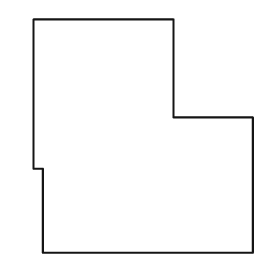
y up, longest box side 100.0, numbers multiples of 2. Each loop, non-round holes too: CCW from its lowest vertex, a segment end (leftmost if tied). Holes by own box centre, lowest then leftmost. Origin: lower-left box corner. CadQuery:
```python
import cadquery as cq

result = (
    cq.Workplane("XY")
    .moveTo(4.0, 0.0)
    .lineTo(94.0, 0.0)
    .lineTo(94.0, 58.0)
    .lineTo(60.0, 58.0)
    .lineTo(60.0, 100.0)
    .lineTo(0.0, 100.0)
    .lineTo(0.0, 36.0)
    .lineTo(4.0, 36.0)
    .close()
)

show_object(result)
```